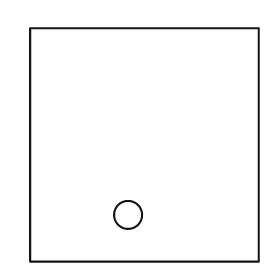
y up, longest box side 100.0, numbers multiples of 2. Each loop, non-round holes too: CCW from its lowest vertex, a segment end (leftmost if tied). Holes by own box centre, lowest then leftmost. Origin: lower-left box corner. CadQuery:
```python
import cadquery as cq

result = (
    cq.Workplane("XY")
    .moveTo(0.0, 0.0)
    .lineTo(98.0, 0.0)
    .lineTo(98.0, 100.0)
    .lineTo(0.0, 100.0)
    .close()
    .moveTo(42.0, 20.0)
    .circle(6.0)
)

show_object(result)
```